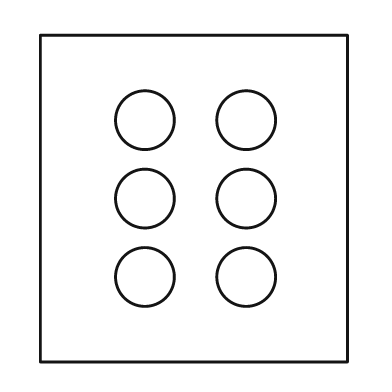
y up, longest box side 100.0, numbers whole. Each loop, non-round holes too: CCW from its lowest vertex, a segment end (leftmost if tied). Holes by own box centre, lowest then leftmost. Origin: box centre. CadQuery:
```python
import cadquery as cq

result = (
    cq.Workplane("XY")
    .moveTo(-47.0, -50.0)
    .lineTo(47.0, -50.0)
    .lineTo(47.0, 50.0)
    .lineTo(-47.0, 50.0)
    .close()
    .moveTo(-15.0, -24.0)
    .circle(9.0)
    .moveTo(16.0, -24.0)
    .circle(9.0)
    .moveTo(-15.0, 0.0)
    .circle(9.0)
    .moveTo(16.0, 0.0)
    .circle(9.0)
    .moveTo(-15.0, 24.0)
    .circle(9.0)
    .moveTo(16.0, 24.0)
    .circle(9.0)
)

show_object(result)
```